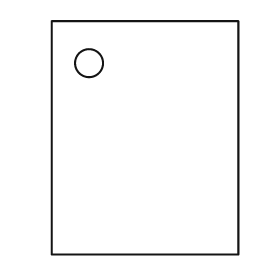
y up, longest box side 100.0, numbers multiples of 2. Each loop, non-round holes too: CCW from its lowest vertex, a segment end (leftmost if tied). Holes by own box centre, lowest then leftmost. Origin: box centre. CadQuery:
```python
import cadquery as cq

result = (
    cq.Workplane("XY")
    .moveTo(-40.0, -50.0)
    .lineTo(40.0, -50.0)
    .lineTo(40.0, 50.0)
    .lineTo(-40.0, 50.0)
    .close()
    .moveTo(-24.0, 32.0)
    .circle(6.0)
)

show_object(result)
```